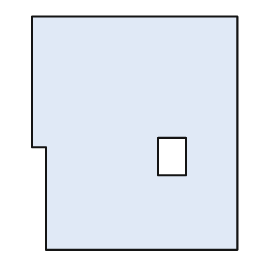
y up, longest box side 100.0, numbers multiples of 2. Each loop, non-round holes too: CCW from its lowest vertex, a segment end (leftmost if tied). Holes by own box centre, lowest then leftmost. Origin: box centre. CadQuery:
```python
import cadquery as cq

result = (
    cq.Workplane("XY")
    .moveTo(-38.0, -50.0)
    .lineTo(44.0, -50.0)
    .lineTo(44.0, 50.0)
    .lineTo(-44.0, 50.0)
    .lineTo(-44.0, -6.0)
    .lineTo(-38.0, -6.0)
    .close()
    .moveTo(10.0, -18.0)
    .lineTo(22.0, -18.0)
    .lineTo(22.0, -2.0)
    .lineTo(10.0, -2.0)
    .close()
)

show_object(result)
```